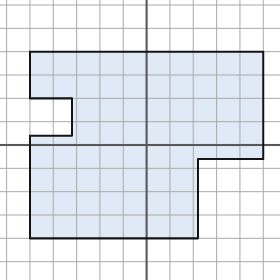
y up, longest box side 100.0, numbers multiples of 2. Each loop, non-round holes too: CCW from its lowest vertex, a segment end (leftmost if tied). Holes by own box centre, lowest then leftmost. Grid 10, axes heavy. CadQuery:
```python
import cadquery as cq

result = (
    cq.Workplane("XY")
    .moveTo(-50.0, -40.0)
    .lineTo(22.0, -40.0)
    .lineTo(22.0, -6.0)
    .lineTo(50.0, -6.0)
    .lineTo(50.0, 40.0)
    .lineTo(-50.0, 40.0)
    .lineTo(-50.0, 20.0)
    .lineTo(-32.0, 20.0)
    .lineTo(-32.0, 4.0)
    .lineTo(-50.0, 4.0)
    .close()
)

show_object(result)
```